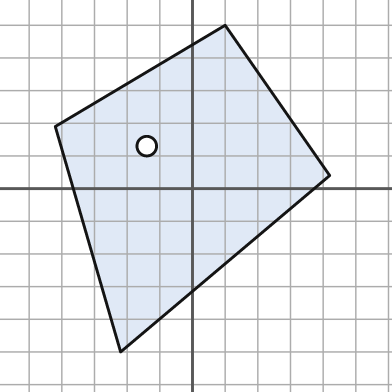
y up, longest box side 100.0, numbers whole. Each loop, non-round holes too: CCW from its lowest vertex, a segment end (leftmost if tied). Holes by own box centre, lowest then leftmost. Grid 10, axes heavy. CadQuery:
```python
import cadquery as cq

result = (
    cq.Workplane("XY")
    .moveTo(-22.0, -50.0)
    .lineTo(42.0, 4.0)
    .lineTo(10.0, 50.0)
    .lineTo(-42.0, 19.0)
    .close()
    .moveTo(-14.0, 13.0)
    .circle(3.0)
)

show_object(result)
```